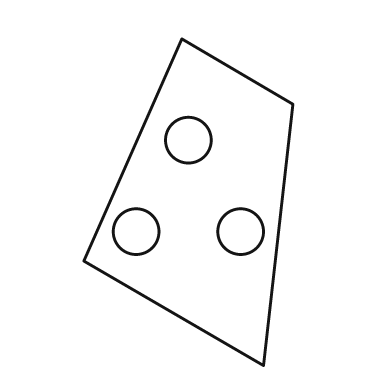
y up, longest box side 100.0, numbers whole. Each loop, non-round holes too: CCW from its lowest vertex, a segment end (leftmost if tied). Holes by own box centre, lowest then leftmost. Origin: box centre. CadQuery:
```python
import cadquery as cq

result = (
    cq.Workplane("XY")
    .moveTo(23.0, -50.0)
    .lineTo(32.0, 30.0)
    .lineTo(-2.0, 50.0)
    .lineTo(-32.0, -18.0)
    .close()
    .moveTo(-16.0, -9.0)
    .circle(7.0)
    .moveTo(16.0, -9.0)
    .circle(7.0)
    .moveTo(0.0, 19.0)
    .circle(7.0)
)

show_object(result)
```